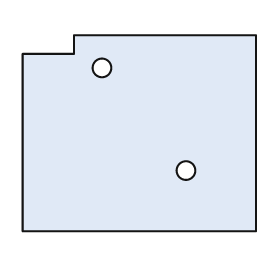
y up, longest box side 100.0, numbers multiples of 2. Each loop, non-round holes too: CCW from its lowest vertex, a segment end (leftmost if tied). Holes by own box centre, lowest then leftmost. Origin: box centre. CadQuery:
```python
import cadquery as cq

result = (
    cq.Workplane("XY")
    .moveTo(-50.0, -42.0)
    .lineTo(50.0, -42.0)
    .lineTo(50.0, 42.0)
    .lineTo(-28.0, 42.0)
    .lineTo(-28.0, 34.0)
    .lineTo(-50.0, 34.0)
    .close()
    .moveTo(20.0, -16.0)
    .circle(4.0)
    .moveTo(-16.0, 28.0)
    .circle(4.0)
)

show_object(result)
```